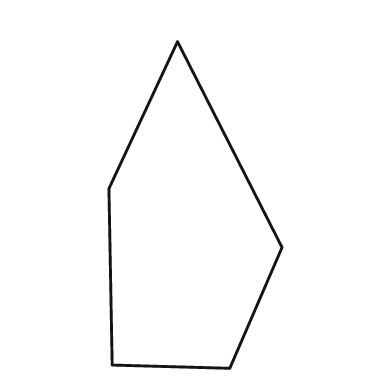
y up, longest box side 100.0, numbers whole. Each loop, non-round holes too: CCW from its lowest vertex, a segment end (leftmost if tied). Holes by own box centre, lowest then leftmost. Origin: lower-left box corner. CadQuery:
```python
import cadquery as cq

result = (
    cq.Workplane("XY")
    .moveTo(37.0, 0.0)
    .lineTo(53.0, 37.0)
    .lineTo(21.0, 100.0)
    .lineTo(0.0, 55.0)
    .lineTo(1.0, 1.0)
    .close()
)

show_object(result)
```